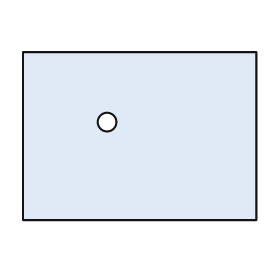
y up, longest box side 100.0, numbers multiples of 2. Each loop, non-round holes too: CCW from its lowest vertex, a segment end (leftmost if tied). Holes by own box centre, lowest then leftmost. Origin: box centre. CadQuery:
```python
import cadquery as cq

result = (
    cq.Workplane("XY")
    .moveTo(-50.0, -36.0)
    .lineTo(50.0, -36.0)
    .lineTo(50.0, 36.0)
    .lineTo(-50.0, 36.0)
    .close()
    .moveTo(-14.0, 6.0)
    .circle(4.0)
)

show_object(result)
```